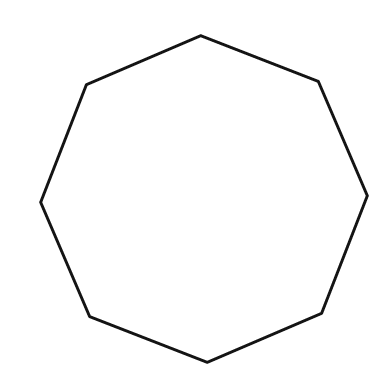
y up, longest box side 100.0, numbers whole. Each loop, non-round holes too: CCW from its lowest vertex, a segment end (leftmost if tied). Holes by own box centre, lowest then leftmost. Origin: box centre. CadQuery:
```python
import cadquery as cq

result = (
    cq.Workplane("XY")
    .moveTo(1.0, -50.0)
    .lineTo(36.0, -35.0)
    .lineTo(50.0, 1.0)
    .lineTo(35.0, 36.0)
    .lineTo(-1.0, 50.0)
    .lineTo(-36.0, 35.0)
    .lineTo(-50.0, -1.0)
    .lineTo(-35.0, -36.0)
    .close()
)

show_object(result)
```